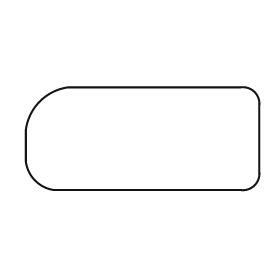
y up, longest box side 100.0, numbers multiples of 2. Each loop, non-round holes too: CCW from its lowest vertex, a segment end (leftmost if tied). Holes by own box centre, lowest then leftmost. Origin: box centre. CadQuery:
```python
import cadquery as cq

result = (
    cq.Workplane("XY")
    .moveTo(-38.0, -22.0)
    .lineTo(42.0, -22.0)
    .threePointArc((48.0, -20.0), (50.0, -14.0))
    .lineTo(50.0, 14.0)
    .threePointArc((48.0, 20.0), (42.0, 22.0))
    .lineTo(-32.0, 22.0)
    .threePointArc((-44.0, 16.0), (-50.0, 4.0))
    .lineTo(-50.0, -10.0)
    .threePointArc((-46.0, -18.0), (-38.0, -22.0))
    .close()
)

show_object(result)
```